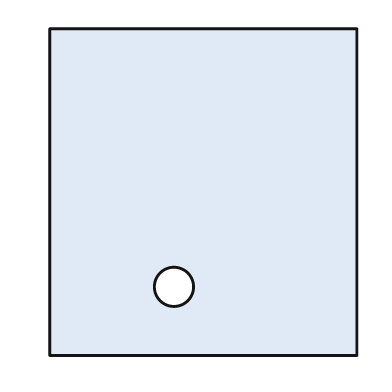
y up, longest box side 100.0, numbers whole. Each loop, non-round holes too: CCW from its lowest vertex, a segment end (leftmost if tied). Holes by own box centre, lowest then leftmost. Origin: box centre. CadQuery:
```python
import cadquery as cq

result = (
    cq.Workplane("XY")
    .moveTo(-47.0, -50.0)
    .lineTo(47.0, -50.0)
    .lineTo(47.0, 50.0)
    .lineTo(-47.0, 50.0)
    .close()
    .moveTo(-9.0, -29.0)
    .circle(6.0)
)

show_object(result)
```